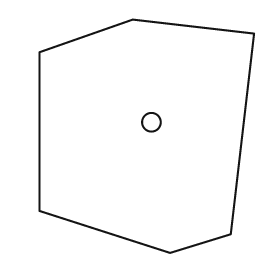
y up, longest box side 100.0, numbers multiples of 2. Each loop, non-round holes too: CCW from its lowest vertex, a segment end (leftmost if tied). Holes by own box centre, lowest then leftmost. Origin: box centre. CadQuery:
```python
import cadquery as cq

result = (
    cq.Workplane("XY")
    .moveTo(10.0, -50.0)
    .lineTo(36.0, -42.0)
    .lineTo(46.0, 44.0)
    .lineTo(-6.0, 50.0)
    .lineTo(-46.0, 36.0)
    .lineTo(-46.0, -32.0)
    .close()
    .moveTo(2.0, 6.0)
    .circle(4.0)
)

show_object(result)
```